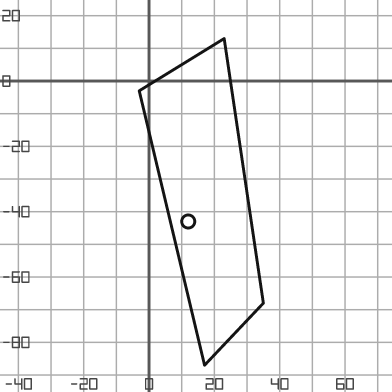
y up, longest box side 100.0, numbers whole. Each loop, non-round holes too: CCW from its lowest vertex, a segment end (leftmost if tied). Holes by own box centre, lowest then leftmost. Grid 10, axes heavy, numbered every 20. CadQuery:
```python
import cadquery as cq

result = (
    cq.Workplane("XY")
    .moveTo(17.0, -87.0)
    .lineTo(35.0, -68.0)
    .lineTo(23.0, 13.0)
    .lineTo(-3.0, -3.0)
    .close()
    .moveTo(12.0, -43.0)
    .circle(2.0)
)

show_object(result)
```